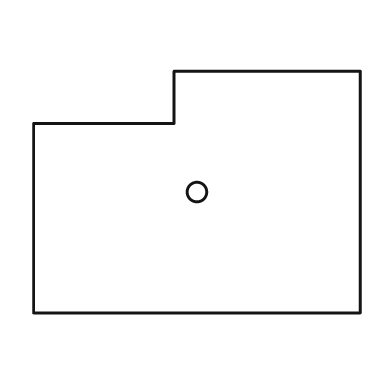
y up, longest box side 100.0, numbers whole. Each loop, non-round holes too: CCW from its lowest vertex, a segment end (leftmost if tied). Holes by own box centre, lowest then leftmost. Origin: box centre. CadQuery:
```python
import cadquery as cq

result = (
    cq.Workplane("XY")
    .moveTo(-50.0, -37.0)
    .lineTo(50.0, -37.0)
    .lineTo(50.0, 37.0)
    .lineTo(-7.0, 37.0)
    .lineTo(-7.0, 21.0)
    .lineTo(-50.0, 21.0)
    .close()
    .moveTo(0.0, 0.0)
    .circle(3.0)
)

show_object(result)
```